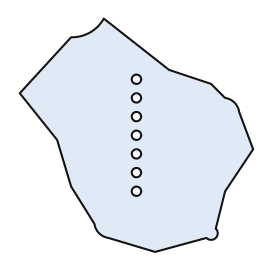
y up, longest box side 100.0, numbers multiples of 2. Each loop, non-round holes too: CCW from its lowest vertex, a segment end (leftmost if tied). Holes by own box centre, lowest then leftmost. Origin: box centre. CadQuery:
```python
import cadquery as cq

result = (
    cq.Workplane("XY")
    .moveTo(8.0, -50.0)
    .lineTo(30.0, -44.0)
    .threePointArc((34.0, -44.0), (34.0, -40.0))
    .lineTo(38.0, -24.0)
    .lineTo(50.0, -6.0)
    .lineTo(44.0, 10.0)
    .threePointArc((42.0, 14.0), (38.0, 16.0))
    .lineTo(32.0, 22.0)
    .lineTo(14.0, 28.0)
    .lineTo(-14.0, 50.0)
    .threePointArc((-20.0, 44.0), (-28.0, 42.0))
    .lineTo(-50.0, 18.0)
    .lineTo(-34.0, -2.0)
    .lineTo(-28.0, -22.0)
    .lineTo(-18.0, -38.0)
    .threePointArc((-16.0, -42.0), (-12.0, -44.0))
    .close()
    .moveTo(0.0, -24.0)
    .circle(2.0)
    .moveTo(0.0, -16.0)
    .circle(2.0)
    .moveTo(0.0, -8.0)
    .circle(2.0)
    .moveTo(0.0, 0.0)
    .circle(2.0)
    .moveTo(0.0, 8.0)
    .circle(2.0)
    .moveTo(0.0, 16.0)
    .circle(2.0)
    .moveTo(0.0, 24.0)
    .circle(2.0)
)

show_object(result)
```